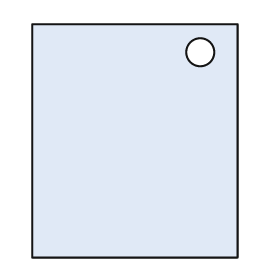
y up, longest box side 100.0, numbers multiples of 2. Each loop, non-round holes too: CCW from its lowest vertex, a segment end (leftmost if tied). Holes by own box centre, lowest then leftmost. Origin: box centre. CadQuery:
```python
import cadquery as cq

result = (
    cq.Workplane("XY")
    .moveTo(-44.0, -50.0)
    .lineTo(44.0, -50.0)
    .lineTo(44.0, 50.0)
    .lineTo(-44.0, 50.0)
    .close()
    .moveTo(28.0, 38.0)
    .circle(6.0)
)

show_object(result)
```